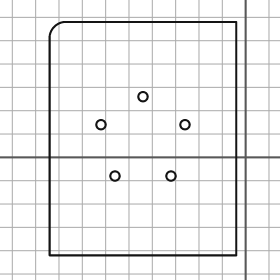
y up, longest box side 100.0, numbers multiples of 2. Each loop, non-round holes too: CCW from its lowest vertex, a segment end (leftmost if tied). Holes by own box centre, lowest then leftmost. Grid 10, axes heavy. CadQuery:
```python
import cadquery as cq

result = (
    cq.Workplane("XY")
    .moveTo(-84.0, -42.0)
    .lineTo(-4.0, -42.0)
    .lineTo(-4.0, 58.0)
    .lineTo(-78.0, 58.0)
    .threePointArc((-82.0, 56.0), (-84.0, 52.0))
    .close()
    .moveTo(-56.0, -8.0)
    .circle(2.0)
    .moveTo(-32.0, -8.0)
    .circle(2.0)
    .moveTo(-62.0, 14.0)
    .circle(2.0)
    .moveTo(-26.0, 14.0)
    .circle(2.0)
    .moveTo(-44.0, 26.0)
    .circle(2.0)
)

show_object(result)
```